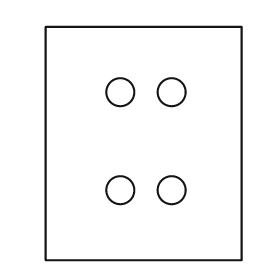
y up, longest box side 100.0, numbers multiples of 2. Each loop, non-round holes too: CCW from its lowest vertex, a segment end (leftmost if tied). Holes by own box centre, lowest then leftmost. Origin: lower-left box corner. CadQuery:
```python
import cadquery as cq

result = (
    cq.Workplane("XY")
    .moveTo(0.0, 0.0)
    .lineTo(84.0, 0.0)
    .lineTo(84.0, 100.0)
    .lineTo(0.0, 100.0)
    .close()
    .moveTo(32.0, 30.0)
    .circle(6.0)
    .moveTo(54.0, 30.0)
    .circle(6.0)
    .moveTo(32.0, 72.0)
    .circle(6.0)
    .moveTo(54.0, 72.0)
    .circle(6.0)
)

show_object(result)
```